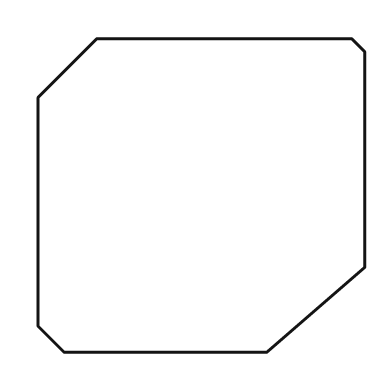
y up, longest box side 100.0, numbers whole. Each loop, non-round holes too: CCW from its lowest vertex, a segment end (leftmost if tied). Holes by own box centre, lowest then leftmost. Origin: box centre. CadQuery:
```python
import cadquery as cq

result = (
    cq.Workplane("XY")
    .moveTo(-42.0, -48.0)
    .lineTo(20.0, -48.0)
    .lineTo(50.0, -22.0)
    .lineTo(50.0, 44.0)
    .lineTo(46.0, 48.0)
    .lineTo(-32.0, 48.0)
    .lineTo(-50.0, 30.0)
    .lineTo(-50.0, -40.0)
    .close()
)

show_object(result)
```